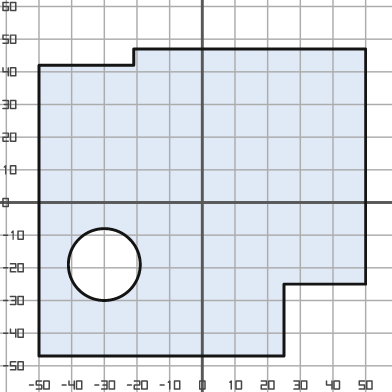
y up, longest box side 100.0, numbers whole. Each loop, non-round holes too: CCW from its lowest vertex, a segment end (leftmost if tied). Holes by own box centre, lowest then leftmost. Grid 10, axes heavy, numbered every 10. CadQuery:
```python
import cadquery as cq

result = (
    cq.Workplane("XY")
    .moveTo(-50.0, -47.0)
    .lineTo(25.0, -47.0)
    .lineTo(25.0, -25.0)
    .lineTo(50.0, -25.0)
    .lineTo(50.0, 47.0)
    .lineTo(-21.0, 47.0)
    .lineTo(-21.0, 42.0)
    .lineTo(-50.0, 42.0)
    .close()
    .moveTo(-30.0, -19.0)
    .circle(11.0)
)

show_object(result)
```